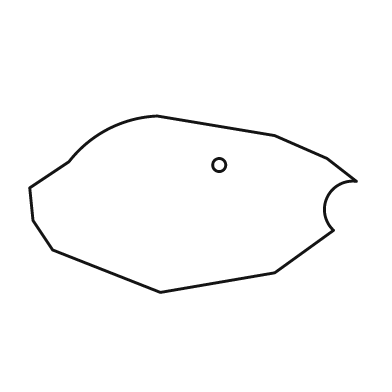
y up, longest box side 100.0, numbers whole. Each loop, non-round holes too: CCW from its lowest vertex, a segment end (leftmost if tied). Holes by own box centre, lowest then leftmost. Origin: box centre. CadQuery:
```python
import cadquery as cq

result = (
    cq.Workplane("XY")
    .moveTo(-10.0, -27.0)
    .lineTo(25.0, -21.0)
    .lineTo(43.0, -8.0)
    .threePointArc((41.0, 2.0), (50.0, 7.0))
    .lineTo(41.0, 14.0)
    .lineTo(25.0, 21.0)
    .lineTo(-11.0, 27.0)
    .threePointArc((-26.0, 23.0), (-38.0, 13.0))
    .lineTo(-50.0, 5.0)
    .lineTo(-49.0, -5.0)
    .lineTo(-43.0, -14.0)
    .close()
    .moveTo(8.0, 12.0)
    .circle(2.0)
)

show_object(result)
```